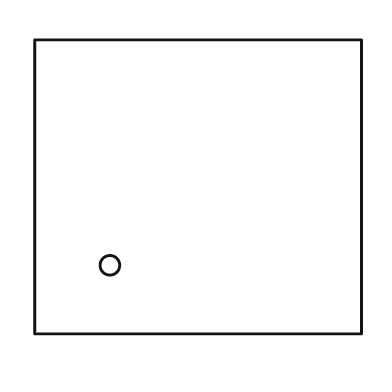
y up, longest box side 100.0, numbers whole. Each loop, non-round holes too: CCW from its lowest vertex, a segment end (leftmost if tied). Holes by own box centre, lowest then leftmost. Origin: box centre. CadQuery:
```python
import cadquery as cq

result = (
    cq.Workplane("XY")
    .moveTo(-50.0, -45.0)
    .lineTo(50.0, -45.0)
    .lineTo(50.0, 45.0)
    .lineTo(-50.0, 45.0)
    .close()
    .moveTo(-27.0, -24.0)
    .circle(3.0)
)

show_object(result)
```